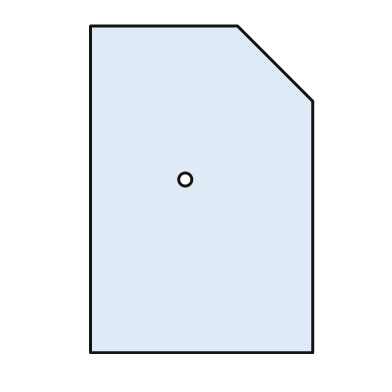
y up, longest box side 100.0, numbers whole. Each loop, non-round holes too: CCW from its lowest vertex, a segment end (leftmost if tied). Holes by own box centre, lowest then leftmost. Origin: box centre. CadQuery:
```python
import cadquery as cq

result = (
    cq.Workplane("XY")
    .moveTo(-34.0, -50.0)
    .lineTo(34.0, -50.0)
    .lineTo(34.0, 27.0)
    .lineTo(11.0, 50.0)
    .lineTo(-34.0, 50.0)
    .close()
    .moveTo(-5.0, 3.0)
    .circle(2.0)
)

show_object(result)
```